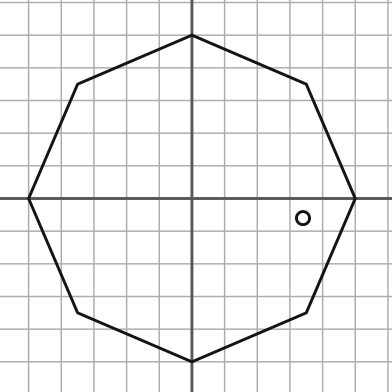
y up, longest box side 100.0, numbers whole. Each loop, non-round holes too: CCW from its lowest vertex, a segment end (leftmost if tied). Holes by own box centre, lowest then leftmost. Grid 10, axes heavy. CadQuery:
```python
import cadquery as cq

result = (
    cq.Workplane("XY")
    .moveTo(0.0, -50.0)
    .lineTo(35.0, -35.0)
    .lineTo(50.0, 0.0)
    .lineTo(35.0, 35.0)
    .lineTo(0.0, 50.0)
    .lineTo(-35.0, 35.0)
    .lineTo(-50.0, 0.0)
    .lineTo(-35.0, -35.0)
    .close()
    .moveTo(34.0, -6.0)
    .circle(2.0)
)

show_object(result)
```